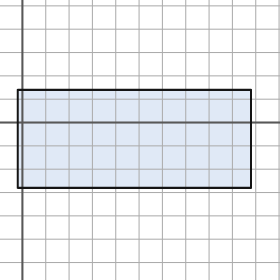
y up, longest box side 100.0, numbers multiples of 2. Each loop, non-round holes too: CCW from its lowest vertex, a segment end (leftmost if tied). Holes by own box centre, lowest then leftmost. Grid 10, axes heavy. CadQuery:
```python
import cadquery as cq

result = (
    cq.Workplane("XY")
    .moveTo(-2.0, -28.0)
    .lineTo(98.0, -28.0)
    .lineTo(98.0, 14.0)
    .lineTo(-2.0, 14.0)
    .close()
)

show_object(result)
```